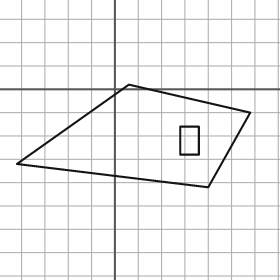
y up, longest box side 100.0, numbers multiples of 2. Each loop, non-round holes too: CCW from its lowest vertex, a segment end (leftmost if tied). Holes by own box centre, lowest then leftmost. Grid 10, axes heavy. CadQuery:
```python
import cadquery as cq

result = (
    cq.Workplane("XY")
    .moveTo(40.0, -42.0)
    .lineTo(58.0, -10.0)
    .lineTo(6.0, 2.0)
    .lineTo(-42.0, -32.0)
    .close()
    .moveTo(28.0, -28.0)
    .lineTo(36.0, -28.0)
    .lineTo(36.0, -16.0)
    .lineTo(28.0, -16.0)
    .close()
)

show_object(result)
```